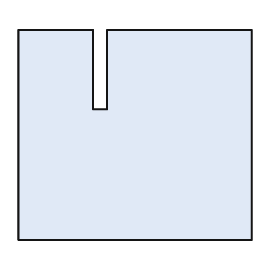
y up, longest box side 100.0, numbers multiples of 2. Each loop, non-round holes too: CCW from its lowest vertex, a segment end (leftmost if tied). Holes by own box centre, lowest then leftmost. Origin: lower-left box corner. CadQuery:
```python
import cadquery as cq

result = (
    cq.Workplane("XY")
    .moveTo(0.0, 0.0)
    .lineTo(100.0, 0.0)
    .lineTo(100.0, 90.0)
    .lineTo(38.0, 90.0)
    .lineTo(38.0, 56.0)
    .lineTo(32.0, 56.0)
    .lineTo(32.0, 90.0)
    .lineTo(0.0, 90.0)
    .close()
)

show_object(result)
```